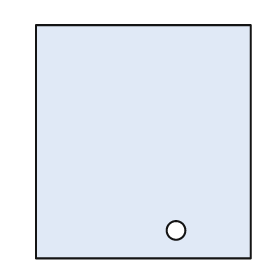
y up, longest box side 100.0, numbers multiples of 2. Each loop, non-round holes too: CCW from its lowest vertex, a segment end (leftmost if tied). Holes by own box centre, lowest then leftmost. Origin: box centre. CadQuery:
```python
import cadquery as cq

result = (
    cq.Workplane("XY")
    .moveTo(-46.0, -50.0)
    .lineTo(46.0, -50.0)
    .lineTo(46.0, 50.0)
    .lineTo(-46.0, 50.0)
    .close()
    .moveTo(14.0, -38.0)
    .circle(4.0)
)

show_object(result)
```